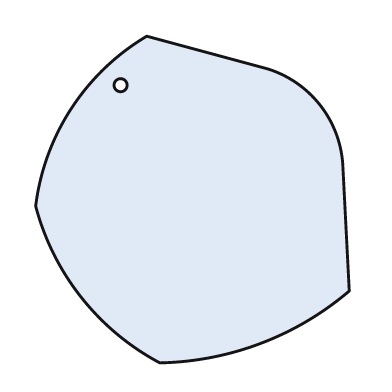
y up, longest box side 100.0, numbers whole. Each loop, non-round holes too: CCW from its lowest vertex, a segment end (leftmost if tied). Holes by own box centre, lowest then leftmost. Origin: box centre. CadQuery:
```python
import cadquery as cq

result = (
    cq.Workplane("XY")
    .moveTo(-10.0, -50.0)
    .threePointArc((21.0, -44.0), (48.0, -28.0))
    .lineTo(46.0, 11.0)
    .threePointArc((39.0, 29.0), (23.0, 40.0))
    .lineTo(-14.0, 50.0)
    .threePointArc((-37.0, 28.0), (-48.0, -2.0))
    .threePointArc((-34.0, -30.0), (-10.0, -50.0))
    .close()
    .moveTo(-22.0, 35.0)
    .circle(2.0)
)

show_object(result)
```